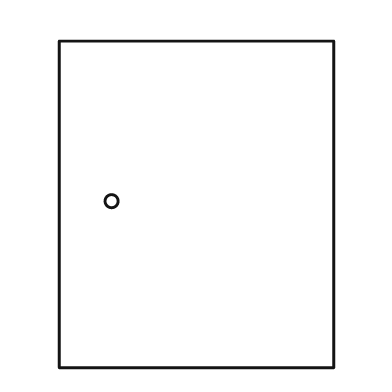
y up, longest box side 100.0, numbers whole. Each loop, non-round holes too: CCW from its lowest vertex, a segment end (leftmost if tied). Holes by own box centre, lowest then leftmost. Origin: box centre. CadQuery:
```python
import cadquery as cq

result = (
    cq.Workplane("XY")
    .moveTo(-42.0, -50.0)
    .lineTo(42.0, -50.0)
    .lineTo(42.0, 50.0)
    .lineTo(-42.0, 50.0)
    .close()
    .moveTo(-26.0, 1.0)
    .circle(2.0)
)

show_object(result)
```